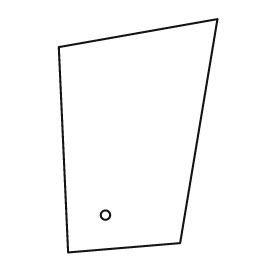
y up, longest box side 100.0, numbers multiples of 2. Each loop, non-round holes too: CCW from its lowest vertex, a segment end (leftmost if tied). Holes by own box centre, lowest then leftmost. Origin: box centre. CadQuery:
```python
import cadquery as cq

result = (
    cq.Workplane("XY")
    .moveTo(-30.0, -50.0)
    .lineTo(18.0, -46.0)
    .lineTo(34.0, 50.0)
    .lineTo(-34.0, 38.0)
    .close()
    .moveTo(-14.0, -34.0)
    .circle(2.0)
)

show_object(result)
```